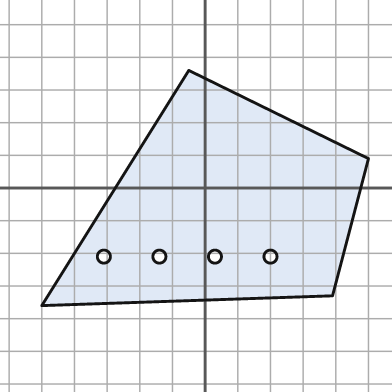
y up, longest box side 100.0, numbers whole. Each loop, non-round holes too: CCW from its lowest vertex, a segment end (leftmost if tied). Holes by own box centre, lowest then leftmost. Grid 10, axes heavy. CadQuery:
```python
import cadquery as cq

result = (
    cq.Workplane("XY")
    .moveTo(-50.0, -36.0)
    .lineTo(39.0, -33.0)
    .lineTo(50.0, 9.0)
    .lineTo(-5.0, 36.0)
    .close()
    .moveTo(-31.0, -21.0)
    .circle(2.0)
    .moveTo(-14.0, -21.0)
    .circle(2.0)
    .moveTo(3.0, -21.0)
    .circle(2.0)
    .moveTo(20.0, -21.0)
    .circle(2.0)
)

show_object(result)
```